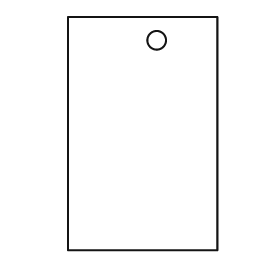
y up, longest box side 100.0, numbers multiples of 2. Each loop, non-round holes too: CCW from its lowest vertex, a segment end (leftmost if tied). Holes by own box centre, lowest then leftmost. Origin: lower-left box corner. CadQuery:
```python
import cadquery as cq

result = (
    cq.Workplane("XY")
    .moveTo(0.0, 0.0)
    .lineTo(64.0, 0.0)
    .lineTo(64.0, 100.0)
    .lineTo(0.0, 100.0)
    .close()
    .moveTo(38.0, 90.0)
    .circle(4.0)
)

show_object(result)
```